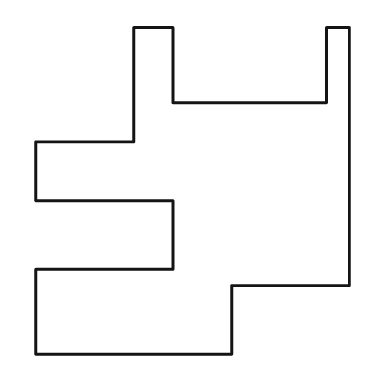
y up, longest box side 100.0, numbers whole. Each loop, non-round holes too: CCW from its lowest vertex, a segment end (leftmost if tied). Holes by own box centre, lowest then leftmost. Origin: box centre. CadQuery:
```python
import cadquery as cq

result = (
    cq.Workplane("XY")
    .moveTo(-48.0, -50.0)
    .lineTo(12.0, -50.0)
    .lineTo(12.0, -29.0)
    .lineTo(48.0, -29.0)
    .lineTo(48.0, 50.0)
    .lineTo(41.0, 50.0)
    .lineTo(41.0, 27.0)
    .lineTo(-6.0, 27.0)
    .lineTo(-6.0, 50.0)
    .lineTo(-18.0, 50.0)
    .lineTo(-18.0, 15.0)
    .lineTo(-48.0, 15.0)
    .lineTo(-48.0, -3.0)
    .lineTo(-6.0, -3.0)
    .lineTo(-6.0, -24.0)
    .lineTo(-48.0, -24.0)
    .close()
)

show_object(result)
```